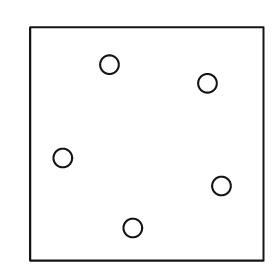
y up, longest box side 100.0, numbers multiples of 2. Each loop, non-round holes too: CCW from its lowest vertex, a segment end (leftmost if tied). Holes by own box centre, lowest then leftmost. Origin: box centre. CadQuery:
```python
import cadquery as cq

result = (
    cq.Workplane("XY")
    .moveTo(-50.0, -50.0)
    .lineTo(50.0, -50.0)
    .lineTo(50.0, 50.0)
    .lineTo(-50.0, 50.0)
    .close()
    .moveTo(-6.0, -36.0)
    .circle(4.0)
    .moveTo(32.0, -18.0)
    .circle(4.0)
    .moveTo(-36.0, -6.0)
    .circle(4.0)
    .moveTo(26.0, 26.0)
    .circle(4.0)
    .moveTo(-16.0, 34.0)
    .circle(4.0)
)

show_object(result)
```